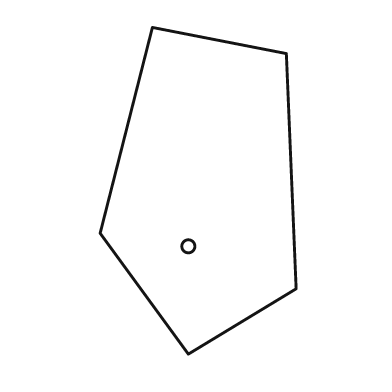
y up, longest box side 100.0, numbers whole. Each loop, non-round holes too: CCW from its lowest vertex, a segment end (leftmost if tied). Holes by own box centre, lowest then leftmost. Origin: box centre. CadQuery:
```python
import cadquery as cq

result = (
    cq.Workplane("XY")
    .moveTo(-3.0, -50.0)
    .lineTo(30.0, -30.0)
    .lineTo(27.0, 42.0)
    .lineTo(-14.0, 50.0)
    .lineTo(-30.0, -13.0)
    .close()
    .moveTo(-3.0, -17.0)
    .circle(2.0)
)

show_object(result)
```